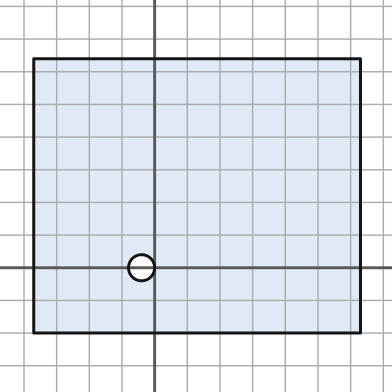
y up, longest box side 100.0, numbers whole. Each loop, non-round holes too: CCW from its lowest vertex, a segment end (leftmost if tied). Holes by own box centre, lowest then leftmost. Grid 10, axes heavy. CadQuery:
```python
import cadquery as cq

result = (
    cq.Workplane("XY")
    .moveTo(-37.0, -20.0)
    .lineTo(63.0, -20.0)
    .lineTo(63.0, 64.0)
    .lineTo(-37.0, 64.0)
    .close()
    .moveTo(-4.0, 0.0)
    .circle(4.0)
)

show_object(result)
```